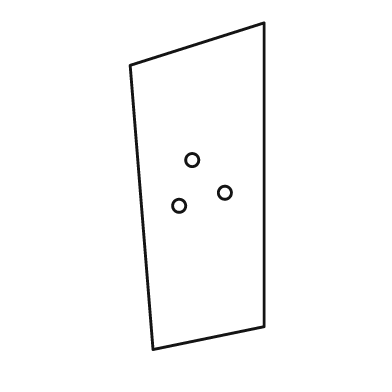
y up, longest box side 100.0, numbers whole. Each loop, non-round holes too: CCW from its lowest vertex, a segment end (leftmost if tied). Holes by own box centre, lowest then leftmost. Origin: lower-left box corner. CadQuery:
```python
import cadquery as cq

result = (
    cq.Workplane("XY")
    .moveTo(7.0, 0.0)
    .lineTo(41.0, 7.0)
    .lineTo(41.0, 100.0)
    .lineTo(0.0, 87.0)
    .close()
    .moveTo(15.0, 44.0)
    .circle(2.0)
    .moveTo(29.0, 48.0)
    .circle(2.0)
    .moveTo(19.0, 58.0)
    .circle(2.0)
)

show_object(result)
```